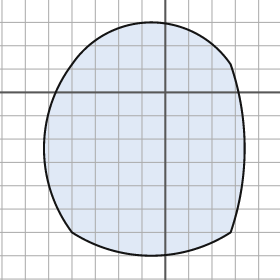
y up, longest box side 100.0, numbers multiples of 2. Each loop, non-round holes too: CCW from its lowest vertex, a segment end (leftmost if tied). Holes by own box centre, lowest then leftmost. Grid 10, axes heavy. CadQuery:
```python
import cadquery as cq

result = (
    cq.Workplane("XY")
    .moveTo(-40.0, -60.0)
    .threePointArc((-6.0, -70.0), (28.0, -60.0))
    .threePointArc((34.0, -24.0), (28.0, 12.0))
    .threePointArc((-6.0, 30.0), (-40.0, 12.0))
    .threePointArc((-52.0, -24.0), (-40.0, -60.0))
    .close()
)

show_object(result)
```